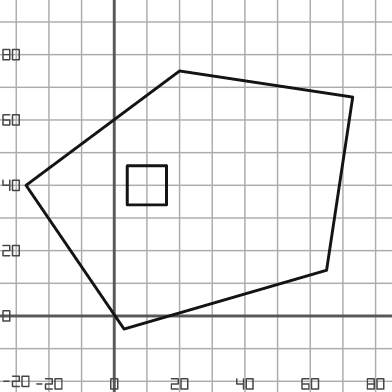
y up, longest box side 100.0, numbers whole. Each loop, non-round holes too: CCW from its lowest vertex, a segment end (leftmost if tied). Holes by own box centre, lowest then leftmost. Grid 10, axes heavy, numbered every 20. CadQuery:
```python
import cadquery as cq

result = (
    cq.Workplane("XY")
    .moveTo(3.0, -4.0)
    .lineTo(65.0, 14.0)
    .lineTo(73.0, 67.0)
    .lineTo(20.0, 75.0)
    .lineTo(-27.0, 40.0)
    .close()
    .moveTo(4.0, 34.0)
    .lineTo(16.0, 34.0)
    .lineTo(16.0, 46.0)
    .lineTo(4.0, 46.0)
    .close()
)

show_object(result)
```